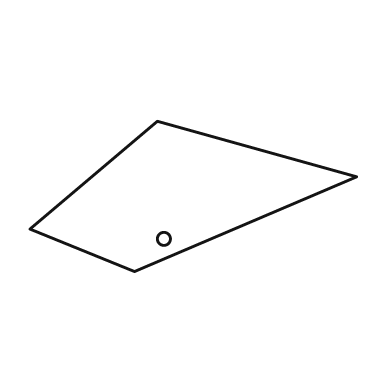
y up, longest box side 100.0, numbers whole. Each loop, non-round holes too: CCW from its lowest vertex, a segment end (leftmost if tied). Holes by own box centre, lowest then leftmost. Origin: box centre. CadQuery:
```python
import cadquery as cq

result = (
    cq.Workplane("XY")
    .moveTo(-18.0, -23.0)
    .lineTo(50.0, 6.0)
    .lineTo(-11.0, 23.0)
    .lineTo(-50.0, -10.0)
    .close()
    .moveTo(-9.0, -13.0)
    .circle(2.0)
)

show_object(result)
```